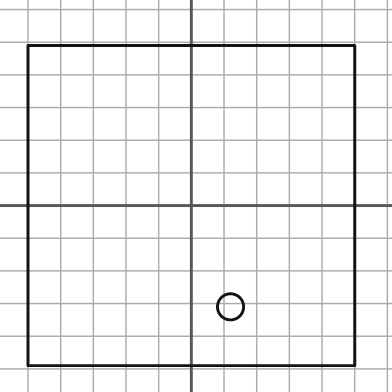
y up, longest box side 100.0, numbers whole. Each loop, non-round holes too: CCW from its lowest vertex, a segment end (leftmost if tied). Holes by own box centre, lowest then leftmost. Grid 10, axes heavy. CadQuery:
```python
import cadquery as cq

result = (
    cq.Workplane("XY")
    .moveTo(-50.0, -49.0)
    .lineTo(50.0, -49.0)
    .lineTo(50.0, 49.0)
    .lineTo(-50.0, 49.0)
    .close()
    .moveTo(12.0, -31.0)
    .circle(4.0)
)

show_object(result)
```